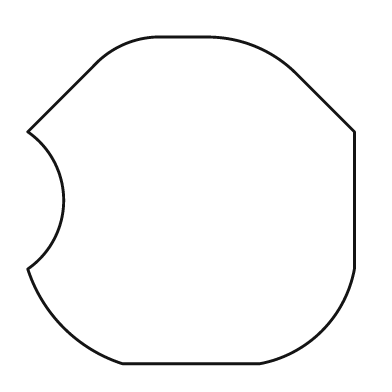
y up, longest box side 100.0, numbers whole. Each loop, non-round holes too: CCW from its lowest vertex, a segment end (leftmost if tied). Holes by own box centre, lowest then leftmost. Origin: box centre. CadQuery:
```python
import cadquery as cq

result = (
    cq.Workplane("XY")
    .moveTo(-21.0, -50.0)
    .lineTo(21.0, -50.0)
    .threePointArc((40.0, -40.0), (50.0, -21.0))
    .lineTo(50.0, 21.0)
    .lineTo(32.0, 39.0)
    .threePointArc((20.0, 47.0), (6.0, 50.0))
    .lineTo(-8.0, 50.0)
    .threePointArc((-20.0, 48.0), (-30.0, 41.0))
    .lineTo(-50.0, 21.0)
    .threePointArc((-39.0, 0.0), (-50.0, -21.0))
    .threePointArc((-39.0, -39.0), (-21.0, -50.0))
    .close()
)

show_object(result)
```